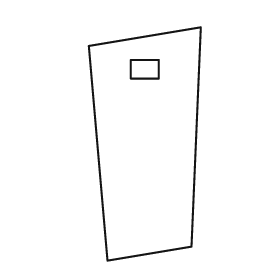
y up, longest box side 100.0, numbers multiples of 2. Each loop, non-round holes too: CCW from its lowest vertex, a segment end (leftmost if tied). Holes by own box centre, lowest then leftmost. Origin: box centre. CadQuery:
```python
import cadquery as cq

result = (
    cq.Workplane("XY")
    .moveTo(-16.0, -50.0)
    .lineTo(20.0, -44.0)
    .lineTo(24.0, 50.0)
    .lineTo(-24.0, 42.0)
    .close()
    .moveTo(-6.0, 28.0)
    .lineTo(6.0, 28.0)
    .lineTo(6.0, 36.0)
    .lineTo(-6.0, 36.0)
    .close()
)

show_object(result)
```